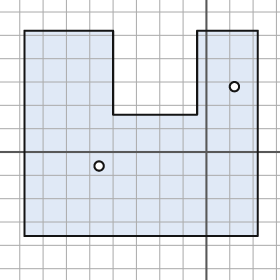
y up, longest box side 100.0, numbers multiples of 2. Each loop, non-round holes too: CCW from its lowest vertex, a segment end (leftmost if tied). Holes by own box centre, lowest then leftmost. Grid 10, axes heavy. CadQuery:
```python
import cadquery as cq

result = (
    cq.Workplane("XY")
    .moveTo(-78.0, -36.0)
    .lineTo(22.0, -36.0)
    .lineTo(22.0, 52.0)
    .lineTo(-4.0, 52.0)
    .lineTo(-4.0, 16.0)
    .lineTo(-40.0, 16.0)
    .lineTo(-40.0, 52.0)
    .lineTo(-78.0, 52.0)
    .close()
    .moveTo(-46.0, -6.0)
    .circle(2.0)
    .moveTo(12.0, 28.0)
    .circle(2.0)
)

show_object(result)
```